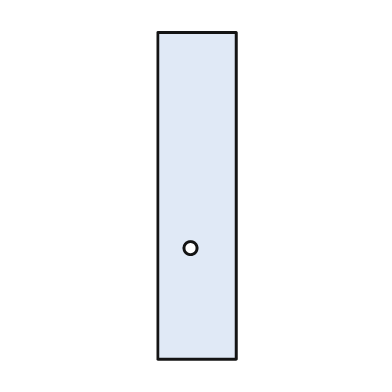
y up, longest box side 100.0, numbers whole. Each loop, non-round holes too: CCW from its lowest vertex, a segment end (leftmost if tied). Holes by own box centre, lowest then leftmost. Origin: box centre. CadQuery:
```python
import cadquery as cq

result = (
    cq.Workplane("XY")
    .moveTo(-12.0, -50.0)
    .lineTo(12.0, -50.0)
    .lineTo(12.0, 50.0)
    .lineTo(-12.0, 50.0)
    .close()
    .moveTo(-2.0, -16.0)
    .circle(2.0)
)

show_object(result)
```